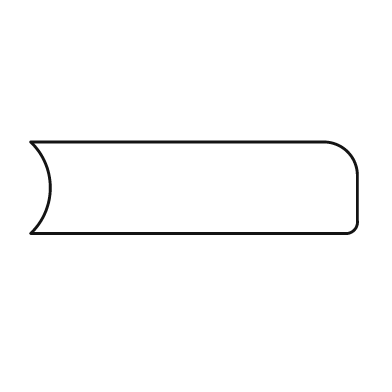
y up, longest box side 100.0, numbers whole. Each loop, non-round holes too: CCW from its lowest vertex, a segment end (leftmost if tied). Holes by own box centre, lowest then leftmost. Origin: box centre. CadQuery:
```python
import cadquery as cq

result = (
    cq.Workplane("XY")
    .moveTo(-50.0, -14.0)
    .lineTo(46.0, -14.0)
    .threePointArc((49.0, -13.0), (50.0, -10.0))
    .lineTo(50.0, 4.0)
    .threePointArc((47.0, 11.0), (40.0, 14.0))
    .lineTo(-50.0, 14.0)
    .threePointArc((-44.0, 0.0), (-50.0, -14.0))
    .close()
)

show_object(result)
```